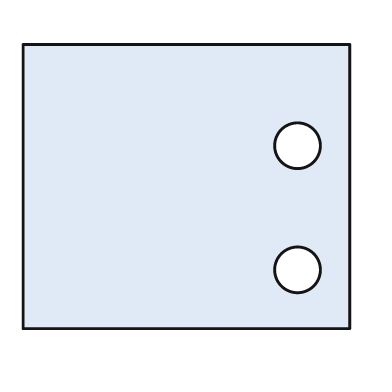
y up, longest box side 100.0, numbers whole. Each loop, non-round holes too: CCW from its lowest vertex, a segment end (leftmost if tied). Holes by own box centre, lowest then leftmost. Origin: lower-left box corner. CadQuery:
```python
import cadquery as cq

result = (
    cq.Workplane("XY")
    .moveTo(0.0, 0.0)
    .lineTo(100.0, 0.0)
    .lineTo(100.0, 87.0)
    .lineTo(0.0, 87.0)
    .close()
    .moveTo(84.0, 18.0)
    .circle(7.0)
    .moveTo(84.0, 56.0)
    .circle(7.0)
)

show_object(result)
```